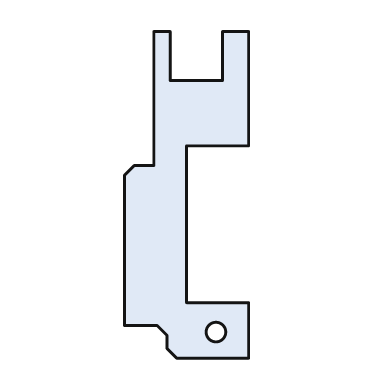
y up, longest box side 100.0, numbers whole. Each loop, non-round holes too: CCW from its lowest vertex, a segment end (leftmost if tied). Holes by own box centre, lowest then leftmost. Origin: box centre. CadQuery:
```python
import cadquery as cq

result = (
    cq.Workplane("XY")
    .moveTo(-3.0, -50.0)
    .lineTo(19.0, -50.0)
    .lineTo(19.0, -33.0)
    .lineTo(0.0, -33.0)
    .lineTo(0.0, 15.0)
    .lineTo(19.0, 15.0)
    .lineTo(19.0, 50.0)
    .lineTo(11.0, 50.0)
    .lineTo(11.0, 35.0)
    .lineTo(-5.0, 35.0)
    .lineTo(-5.0, 50.0)
    .lineTo(-10.0, 50.0)
    .lineTo(-10.0, 9.0)
    .lineTo(-16.0, 9.0)
    .lineTo(-19.0, 6.0)
    .lineTo(-19.0, -40.0)
    .lineTo(-9.0, -40.0)
    .lineTo(-6.0, -43.0)
    .lineTo(-6.0, -47.0)
    .close()
    .moveTo(9.0, -42.0)
    .circle(3.0)
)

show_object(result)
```